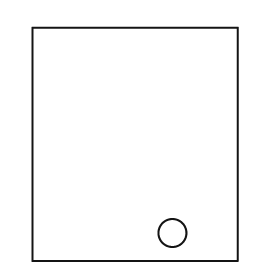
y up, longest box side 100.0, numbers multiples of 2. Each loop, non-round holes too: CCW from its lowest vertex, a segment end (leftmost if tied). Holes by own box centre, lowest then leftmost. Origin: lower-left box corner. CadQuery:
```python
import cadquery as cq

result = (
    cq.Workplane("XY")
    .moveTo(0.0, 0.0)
    .lineTo(88.0, 0.0)
    .lineTo(88.0, 100.0)
    .lineTo(0.0, 100.0)
    .close()
    .moveTo(60.0, 12.0)
    .circle(6.0)
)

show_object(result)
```